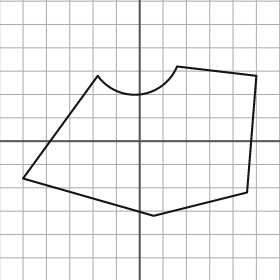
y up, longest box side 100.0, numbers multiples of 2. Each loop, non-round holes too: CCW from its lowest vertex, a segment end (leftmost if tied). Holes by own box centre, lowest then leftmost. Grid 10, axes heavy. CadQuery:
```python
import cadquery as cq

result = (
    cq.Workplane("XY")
    .moveTo(6.0, -32.0)
    .lineTo(46.0, -22.0)
    .lineTo(50.0, 28.0)
    .lineTo(16.0, 32.0)
    .threePointArc((0.0, 20.0), (-18.0, 28.0))
    .lineTo(-50.0, -16.0)
    .close()
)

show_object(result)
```